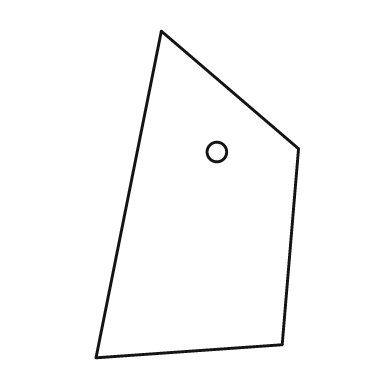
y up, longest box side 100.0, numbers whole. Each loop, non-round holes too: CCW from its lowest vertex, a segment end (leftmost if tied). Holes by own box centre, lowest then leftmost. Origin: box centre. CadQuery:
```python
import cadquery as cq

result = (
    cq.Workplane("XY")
    .moveTo(-31.0, -50.0)
    .lineTo(26.0, -46.0)
    .lineTo(31.0, 14.0)
    .lineTo(-11.0, 50.0)
    .close()
    .moveTo(6.0, 13.0)
    .circle(3.0)
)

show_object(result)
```